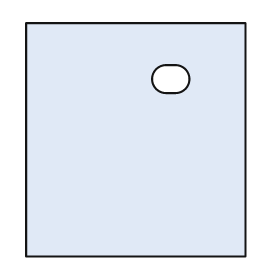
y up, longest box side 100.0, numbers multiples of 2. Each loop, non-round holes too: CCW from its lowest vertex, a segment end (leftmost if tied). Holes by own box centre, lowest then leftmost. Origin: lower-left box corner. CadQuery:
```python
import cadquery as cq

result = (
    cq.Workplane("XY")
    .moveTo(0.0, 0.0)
    .lineTo(94.0, 0.0)
    .lineTo(94.0, 100.0)
    .lineTo(0.0, 100.0)
    .close()
    .moveTo(60.0, 70.0)
    .lineTo(64.0, 70.0)
    .threePointArc((70.0, 76.0), (64.0, 82.0))
    .lineTo(60.0, 82.0)
    .threePointArc((54.0, 76.0), (60.0, 70.0))
    .close()
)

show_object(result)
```